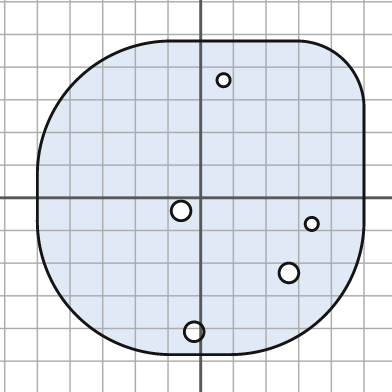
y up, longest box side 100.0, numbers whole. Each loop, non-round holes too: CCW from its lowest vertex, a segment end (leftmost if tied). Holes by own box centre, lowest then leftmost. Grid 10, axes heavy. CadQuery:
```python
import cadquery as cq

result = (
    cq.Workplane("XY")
    .moveTo(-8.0, -48.0)
    .lineTo(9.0, -48.0)
    .threePointArc((38.0, -36.0), (50.0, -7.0))
    .lineTo(50.0, 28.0)
    .threePointArc((44.0, 42.0), (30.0, 48.0))
    .lineTo(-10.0, 48.0)
    .threePointArc((-38.0, 36.0), (-50.0, 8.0))
    .lineTo(-50.0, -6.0)
    .threePointArc((-38.0, -36.0), (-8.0, -48.0))
    .close()
    .moveTo(-2.0, -41.0)
    .circle(3.0)
    .moveTo(27.0, -23.0)
    .circle(3.0)
    .moveTo(34.0, -8.0)
    .circle(2.0)
    .moveTo(-6.0, -4.0)
    .circle(3.0)
    .moveTo(7.0, 36.0)
    .circle(2.0)
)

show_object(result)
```